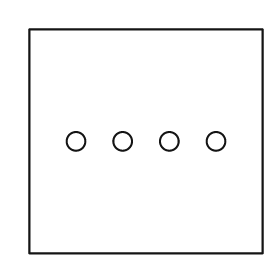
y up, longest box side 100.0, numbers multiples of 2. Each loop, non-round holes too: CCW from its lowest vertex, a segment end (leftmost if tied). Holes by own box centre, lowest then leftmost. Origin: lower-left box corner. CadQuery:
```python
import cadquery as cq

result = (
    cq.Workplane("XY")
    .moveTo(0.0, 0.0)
    .lineTo(100.0, 0.0)
    .lineTo(100.0, 96.0)
    .lineTo(0.0, 96.0)
    .close()
    .moveTo(20.0, 48.0)
    .circle(4.0)
    .moveTo(40.0, 48.0)
    .circle(4.0)
    .moveTo(60.0, 48.0)
    .circle(4.0)
    .moveTo(80.0, 48.0)
    .circle(4.0)
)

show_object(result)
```